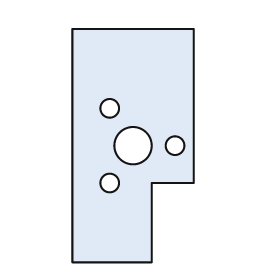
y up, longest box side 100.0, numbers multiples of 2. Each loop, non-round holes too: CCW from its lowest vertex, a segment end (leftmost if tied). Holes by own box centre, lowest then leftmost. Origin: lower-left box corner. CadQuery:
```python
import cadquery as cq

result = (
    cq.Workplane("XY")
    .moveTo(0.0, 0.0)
    .lineTo(34.0, 0.0)
    .lineTo(34.0, 34.0)
    .lineTo(52.0, 34.0)
    .lineTo(52.0, 100.0)
    .lineTo(0.0, 100.0)
    .close()
    .moveTo(16.0, 34.0)
    .circle(4.0)
    .moveTo(26.0, 50.0)
    .circle(8.0)
    .moveTo(44.0, 50.0)
    .circle(4.0)
    .moveTo(16.0, 66.0)
    .circle(4.0)
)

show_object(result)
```